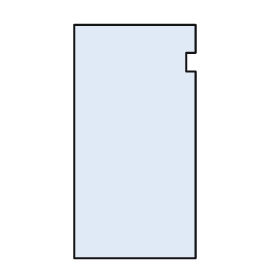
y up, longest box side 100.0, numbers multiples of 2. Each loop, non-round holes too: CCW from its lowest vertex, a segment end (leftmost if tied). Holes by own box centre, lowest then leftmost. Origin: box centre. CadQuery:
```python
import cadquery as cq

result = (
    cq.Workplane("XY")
    .moveTo(-26.0, -50.0)
    .lineTo(26.0, -50.0)
    .lineTo(26.0, 30.0)
    .lineTo(22.0, 30.0)
    .lineTo(22.0, 38.0)
    .lineTo(26.0, 38.0)
    .lineTo(26.0, 50.0)
    .lineTo(-26.0, 50.0)
    .close()
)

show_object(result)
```